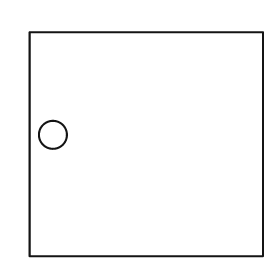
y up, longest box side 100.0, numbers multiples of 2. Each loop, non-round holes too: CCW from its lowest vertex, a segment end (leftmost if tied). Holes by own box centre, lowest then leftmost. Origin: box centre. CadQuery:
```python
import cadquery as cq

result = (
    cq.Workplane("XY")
    .moveTo(-50.0, -48.0)
    .lineTo(50.0, -48.0)
    .lineTo(50.0, 48.0)
    .lineTo(-50.0, 48.0)
    .close()
    .moveTo(-40.0, 4.0)
    .circle(6.0)
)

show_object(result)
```